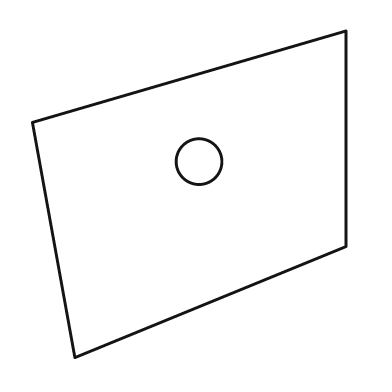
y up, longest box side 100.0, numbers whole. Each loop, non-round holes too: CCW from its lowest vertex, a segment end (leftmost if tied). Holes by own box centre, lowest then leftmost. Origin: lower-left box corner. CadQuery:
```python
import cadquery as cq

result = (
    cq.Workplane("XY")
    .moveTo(13.0, 0.0)
    .lineTo(96.0, 34.0)
    .lineTo(96.0, 100.0)
    .lineTo(0.0, 72.0)
    .close()
    .moveTo(51.0, 60.0)
    .circle(7.0)
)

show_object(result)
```